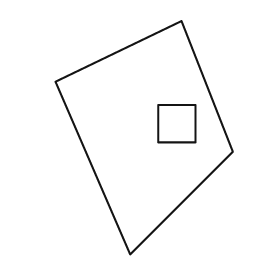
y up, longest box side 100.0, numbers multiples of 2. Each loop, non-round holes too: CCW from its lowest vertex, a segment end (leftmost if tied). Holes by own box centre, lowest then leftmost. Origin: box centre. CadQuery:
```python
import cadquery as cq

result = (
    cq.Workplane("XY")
    .moveTo(-6.0, -50.0)
    .lineTo(38.0, -6.0)
    .lineTo(16.0, 50.0)
    .lineTo(-38.0, 24.0)
    .close()
    .moveTo(6.0, -2.0)
    .lineTo(22.0, -2.0)
    .lineTo(22.0, 14.0)
    .lineTo(6.0, 14.0)
    .close()
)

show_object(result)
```